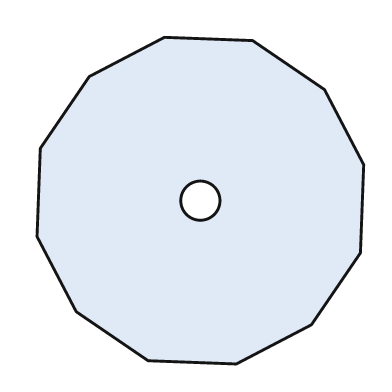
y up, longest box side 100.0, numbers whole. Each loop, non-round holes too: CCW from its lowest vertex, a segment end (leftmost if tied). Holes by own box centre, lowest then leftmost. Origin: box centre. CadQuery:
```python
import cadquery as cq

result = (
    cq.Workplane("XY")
    .moveTo(11.0, -50.0)
    .lineTo(34.0, -38.0)
    .lineTo(49.0, -16.0)
    .lineTo(50.0, 11.0)
    .lineTo(38.0, 34.0)
    .lineTo(16.0, 49.0)
    .lineTo(-11.0, 50.0)
    .lineTo(-34.0, 38.0)
    .lineTo(-49.0, 16.0)
    .lineTo(-50.0, -11.0)
    .lineTo(-38.0, -34.0)
    .lineTo(-16.0, -49.0)
    .close()
    .moveTo(0.0, 0.0)
    .circle(6.0)
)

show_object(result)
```